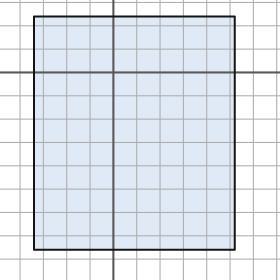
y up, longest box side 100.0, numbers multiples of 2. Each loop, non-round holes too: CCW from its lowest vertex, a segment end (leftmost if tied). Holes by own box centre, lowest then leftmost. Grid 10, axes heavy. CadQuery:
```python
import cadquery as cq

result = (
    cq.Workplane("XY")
    .moveTo(-34.0, -76.0)
    .lineTo(52.0, -76.0)
    .lineTo(52.0, 24.0)
    .lineTo(-34.0, 24.0)
    .close()
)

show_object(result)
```